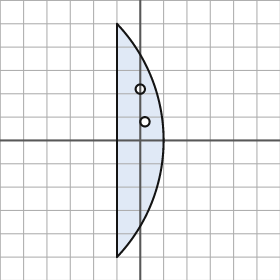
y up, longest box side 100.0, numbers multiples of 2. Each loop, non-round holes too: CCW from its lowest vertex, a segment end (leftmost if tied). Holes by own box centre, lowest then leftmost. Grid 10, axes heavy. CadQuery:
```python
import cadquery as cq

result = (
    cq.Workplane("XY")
    .moveTo(-10.0, -50.0)
    .threePointArc((10.0, 0.0), (-10.0, 50.0))
    .close()
    .moveTo(2.0, 8.0)
    .circle(2.0)
    .moveTo(0.0, 22.0)
    .circle(2.0)
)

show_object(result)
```